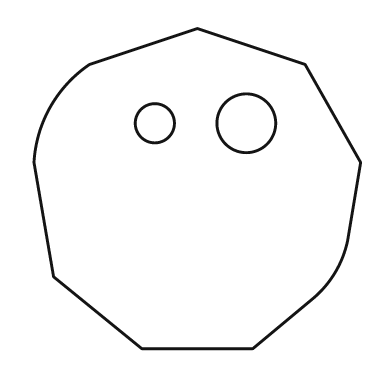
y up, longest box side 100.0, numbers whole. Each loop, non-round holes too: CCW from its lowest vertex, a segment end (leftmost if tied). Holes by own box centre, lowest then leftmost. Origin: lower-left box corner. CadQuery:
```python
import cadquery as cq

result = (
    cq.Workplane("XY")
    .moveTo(33.0, 0.0)
    .lineTo(67.0, 0.0)
    .lineTo(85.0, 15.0)
    .threePointArc((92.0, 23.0), (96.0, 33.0))
    .lineTo(100.0, 57.0)
    .lineTo(83.0, 87.0)
    .lineTo(50.0, 98.0)
    .lineTo(17.0, 87.0)
    .threePointArc((5.0, 74.0), (0.0, 57.0))
    .lineTo(6.0, 22.0)
    .close()
    .moveTo(37.0, 69.0)
    .circle(6.0)
    .moveTo(65.0, 69.0)
    .circle(9.0)
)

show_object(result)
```